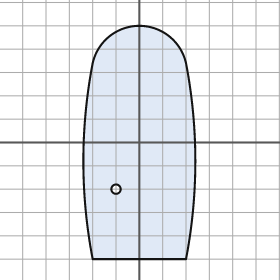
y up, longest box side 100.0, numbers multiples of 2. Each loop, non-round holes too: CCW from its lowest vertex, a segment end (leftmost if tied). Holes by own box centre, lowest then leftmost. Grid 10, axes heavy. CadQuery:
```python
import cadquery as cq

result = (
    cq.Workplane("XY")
    .moveTo(-20.0, -50.0)
    .lineTo(20.0, -50.0)
    .threePointArc((24.0, -8.0), (20.0, 34.0))
    .threePointArc((0.0, 50.0), (-20.0, 34.0))
    .threePointArc((-24.0, -8.0), (-20.0, -50.0))
    .close()
    .moveTo(-10.0, -20.0)
    .circle(2.0)
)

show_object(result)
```